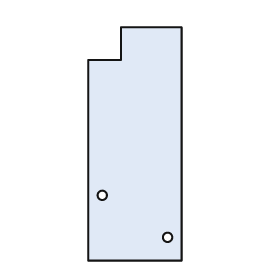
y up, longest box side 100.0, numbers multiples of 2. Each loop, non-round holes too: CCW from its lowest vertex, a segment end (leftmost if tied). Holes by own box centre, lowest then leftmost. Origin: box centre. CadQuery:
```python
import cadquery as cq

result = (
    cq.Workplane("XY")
    .moveTo(-20.0, -50.0)
    .lineTo(20.0, -50.0)
    .lineTo(20.0, 50.0)
    .lineTo(-6.0, 50.0)
    .lineTo(-6.0, 36.0)
    .lineTo(-20.0, 36.0)
    .close()
    .moveTo(14.0, -40.0)
    .circle(2.0)
    .moveTo(-14.0, -22.0)
    .circle(2.0)
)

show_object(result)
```